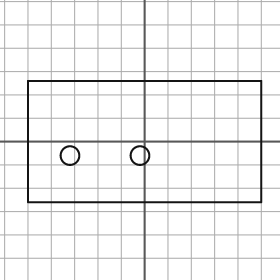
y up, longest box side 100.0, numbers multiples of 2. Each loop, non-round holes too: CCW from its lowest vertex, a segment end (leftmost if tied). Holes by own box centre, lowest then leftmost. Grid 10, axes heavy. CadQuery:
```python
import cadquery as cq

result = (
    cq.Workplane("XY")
    .moveTo(-50.0, -26.0)
    .lineTo(50.0, -26.0)
    .lineTo(50.0, 26.0)
    .lineTo(-50.0, 26.0)
    .close()
    .moveTo(-32.0, -6.0)
    .circle(4.0)
    .moveTo(-2.0, -6.0)
    .circle(4.0)
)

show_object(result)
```